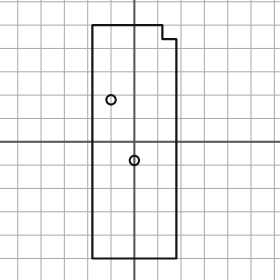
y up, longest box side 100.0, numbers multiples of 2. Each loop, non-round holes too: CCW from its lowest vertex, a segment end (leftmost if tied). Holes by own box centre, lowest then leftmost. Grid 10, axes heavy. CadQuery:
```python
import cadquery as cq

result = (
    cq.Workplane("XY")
    .moveTo(-18.0, -50.0)
    .lineTo(18.0, -50.0)
    .lineTo(18.0, 44.0)
    .lineTo(12.0, 44.0)
    .lineTo(12.0, 50.0)
    .lineTo(-18.0, 50.0)
    .close()
    .moveTo(0.0, -8.0)
    .circle(2.0)
    .moveTo(-10.0, 18.0)
    .circle(2.0)
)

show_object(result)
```